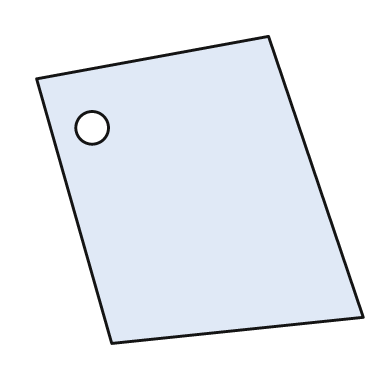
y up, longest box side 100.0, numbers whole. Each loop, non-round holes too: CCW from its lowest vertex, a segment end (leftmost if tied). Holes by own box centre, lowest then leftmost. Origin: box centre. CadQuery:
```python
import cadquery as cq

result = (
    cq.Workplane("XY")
    .moveTo(-27.0, -47.0)
    .lineTo(50.0, -39.0)
    .lineTo(21.0, 47.0)
    .lineTo(-50.0, 34.0)
    .close()
    .moveTo(-33.0, 19.0)
    .circle(5.0)
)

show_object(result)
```